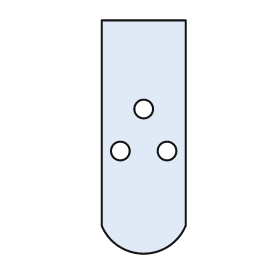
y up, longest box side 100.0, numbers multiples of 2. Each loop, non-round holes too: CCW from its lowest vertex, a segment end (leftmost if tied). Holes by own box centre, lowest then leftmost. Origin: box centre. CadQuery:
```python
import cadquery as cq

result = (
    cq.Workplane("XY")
    .moveTo(-18.0, -38.0)
    .threePointArc((0.0, -50.0), (18.0, -38.0))
    .lineTo(18.0, 50.0)
    .lineTo(-18.0, 50.0)
    .close()
    .moveTo(-10.0, -6.0)
    .circle(4.0)
    .moveTo(10.0, -6.0)
    .circle(4.0)
    .moveTo(0.0, 12.0)
    .circle(4.0)
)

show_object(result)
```